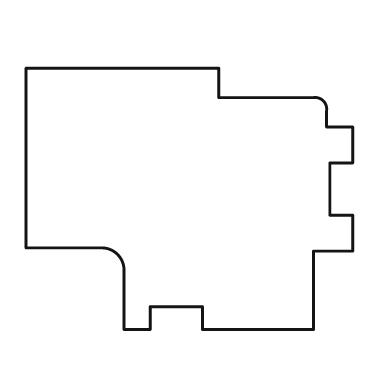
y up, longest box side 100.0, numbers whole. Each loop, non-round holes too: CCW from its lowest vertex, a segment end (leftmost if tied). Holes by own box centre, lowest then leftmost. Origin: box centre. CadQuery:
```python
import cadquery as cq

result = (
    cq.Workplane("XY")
    .moveTo(-20.0, -40.0)
    .lineTo(-12.0, -40.0)
    .lineTo(-12.0, -33.0)
    .lineTo(4.0, -33.0)
    .lineTo(4.0, -40.0)
    .lineTo(38.0, -40.0)
    .lineTo(38.0, -16.0)
    .lineTo(50.0, -16.0)
    .lineTo(50.0, -5.0)
    .lineTo(43.0, -5.0)
    .lineTo(43.0, 11.0)
    .lineTo(50.0, 11.0)
    .lineTo(50.0, 22.0)
    .lineTo(42.0, 22.0)
    .lineTo(42.0, 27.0)
    .threePointArc((41.0, 30.0), (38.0, 31.0))
    .lineTo(9.0, 31.0)
    .lineTo(9.0, 40.0)
    .lineTo(-50.0, 40.0)
    .lineTo(-50.0, -15.0)
    .lineTo(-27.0, -15.0)
    .threePointArc((-22.0, -17.0), (-20.0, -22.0))
    .close()
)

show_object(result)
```